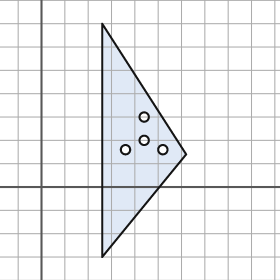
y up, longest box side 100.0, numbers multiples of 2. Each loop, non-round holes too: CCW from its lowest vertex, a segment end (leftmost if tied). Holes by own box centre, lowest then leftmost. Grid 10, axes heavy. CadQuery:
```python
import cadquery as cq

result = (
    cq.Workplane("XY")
    .moveTo(26.0, -30.0)
    .lineTo(62.0, 14.0)
    .lineTo(26.0, 70.0)
    .close()
    .moveTo(36.0, 16.0)
    .circle(2.0)
    .moveTo(52.0, 16.0)
    .circle(2.0)
    .moveTo(44.0, 20.0)
    .circle(2.0)
    .moveTo(44.0, 30.0)
    .circle(2.0)
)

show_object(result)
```